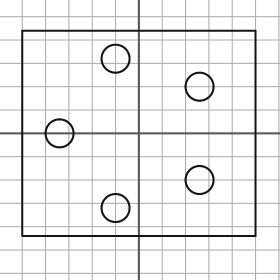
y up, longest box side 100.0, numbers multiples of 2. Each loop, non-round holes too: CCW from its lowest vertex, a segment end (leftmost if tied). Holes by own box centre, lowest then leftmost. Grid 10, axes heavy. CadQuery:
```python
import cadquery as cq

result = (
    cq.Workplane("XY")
    .moveTo(-50.0, -44.0)
    .lineTo(50.0, -44.0)
    .lineTo(50.0, 44.0)
    .lineTo(-50.0, 44.0)
    .close()
    .moveTo(-10.0, -32.0)
    .circle(6.0)
    .moveTo(26.0, -20.0)
    .circle(6.0)
    .moveTo(-34.0, 0.0)
    .circle(6.0)
    .moveTo(26.0, 20.0)
    .circle(6.0)
    .moveTo(-10.0, 32.0)
    .circle(6.0)
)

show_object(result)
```